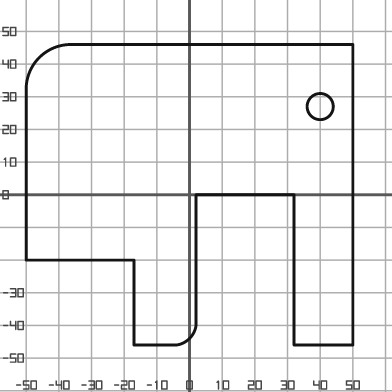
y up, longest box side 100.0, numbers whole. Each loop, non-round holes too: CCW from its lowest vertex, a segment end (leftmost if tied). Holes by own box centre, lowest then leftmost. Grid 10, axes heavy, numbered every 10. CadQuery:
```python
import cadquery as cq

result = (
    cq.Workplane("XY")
    .moveTo(-17.0, -46.0)
    .lineTo(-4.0, -46.0)
    .threePointArc((0.0, -44.0), (2.0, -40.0))
    .lineTo(2.0, 0.0)
    .lineTo(32.0, 0.0)
    .lineTo(32.0, -46.0)
    .lineTo(50.0, -46.0)
    .lineTo(50.0, 46.0)
    .lineTo(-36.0, 46.0)
    .threePointArc((-46.0, 42.0), (-50.0, 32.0))
    .lineTo(-50.0, -20.0)
    .lineTo(-17.0, -20.0)
    .close()
    .moveTo(40.0, 27.0)
    .circle(4.0)
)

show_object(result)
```